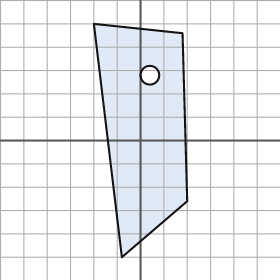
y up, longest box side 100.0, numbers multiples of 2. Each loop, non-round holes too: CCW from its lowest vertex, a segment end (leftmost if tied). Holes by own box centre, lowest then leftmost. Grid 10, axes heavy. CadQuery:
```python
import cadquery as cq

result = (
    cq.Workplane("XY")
    .moveTo(-8.0, -50.0)
    .lineTo(20.0, -26.0)
    .lineTo(18.0, 46.0)
    .lineTo(-20.0, 50.0)
    .close()
    .moveTo(4.0, 28.0)
    .circle(4.0)
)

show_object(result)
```